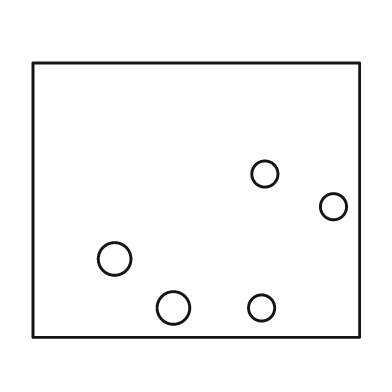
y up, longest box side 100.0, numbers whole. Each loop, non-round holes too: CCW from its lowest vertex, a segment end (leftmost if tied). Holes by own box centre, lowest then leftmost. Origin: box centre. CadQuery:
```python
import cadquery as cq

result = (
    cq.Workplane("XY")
    .moveTo(-50.0, -42.0)
    .lineTo(50.0, -42.0)
    .lineTo(50.0, 42.0)
    .lineTo(-50.0, 42.0)
    .close()
    .moveTo(-7.0, -33.0)
    .circle(5.0)
    .moveTo(20.0, -33.0)
    .circle(4.0)
    .moveTo(-25.0, -18.0)
    .circle(5.0)
    .moveTo(42.0, -2.0)
    .circle(4.0)
    .moveTo(21.0, 8.0)
    .circle(4.0)
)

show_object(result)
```